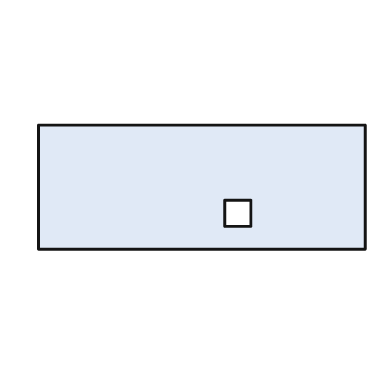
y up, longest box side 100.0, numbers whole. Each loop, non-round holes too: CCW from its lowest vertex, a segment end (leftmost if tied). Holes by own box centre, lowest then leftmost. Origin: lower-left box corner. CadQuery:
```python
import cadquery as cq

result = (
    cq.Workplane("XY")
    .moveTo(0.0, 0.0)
    .lineTo(100.0, 0.0)
    .lineTo(100.0, 38.0)
    .lineTo(0.0, 38.0)
    .close()
    .moveTo(57.0, 7.0)
    .lineTo(65.0, 7.0)
    .lineTo(65.0, 15.0)
    .lineTo(57.0, 15.0)
    .close()
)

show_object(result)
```